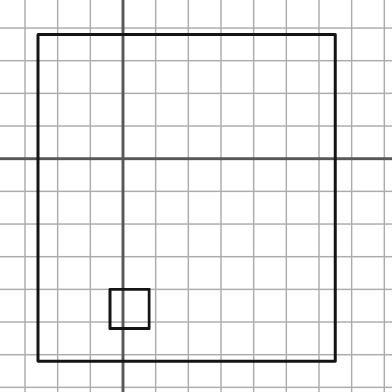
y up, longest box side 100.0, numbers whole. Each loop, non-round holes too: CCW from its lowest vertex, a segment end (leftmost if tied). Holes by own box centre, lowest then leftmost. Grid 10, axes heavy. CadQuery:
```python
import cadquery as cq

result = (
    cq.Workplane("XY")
    .moveTo(-26.0, -62.0)
    .lineTo(65.0, -62.0)
    .lineTo(65.0, 38.0)
    .lineTo(-26.0, 38.0)
    .close()
    .moveTo(-4.0, -52.0)
    .lineTo(8.0, -52.0)
    .lineTo(8.0, -40.0)
    .lineTo(-4.0, -40.0)
    .close()
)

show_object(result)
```